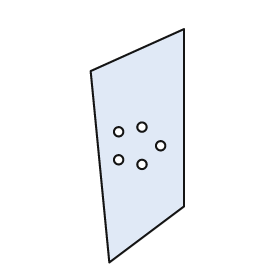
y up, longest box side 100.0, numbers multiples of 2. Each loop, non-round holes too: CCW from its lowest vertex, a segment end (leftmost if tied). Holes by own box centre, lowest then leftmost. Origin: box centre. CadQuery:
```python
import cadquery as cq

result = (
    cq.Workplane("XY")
    .moveTo(-12.0, -50.0)
    .lineTo(20.0, -26.0)
    .lineTo(20.0, 50.0)
    .lineTo(-20.0, 32.0)
    .close()
    .moveTo(2.0, -8.0)
    .circle(2.0)
    .moveTo(-8.0, -6.0)
    .circle(2.0)
    .moveTo(10.0, 0.0)
    .circle(2.0)
    .moveTo(-8.0, 6.0)
    .circle(2.0)
    .moveTo(2.0, 8.0)
    .circle(2.0)
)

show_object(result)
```